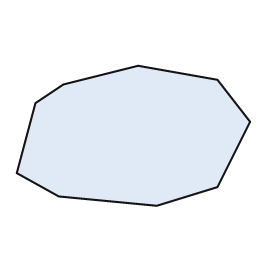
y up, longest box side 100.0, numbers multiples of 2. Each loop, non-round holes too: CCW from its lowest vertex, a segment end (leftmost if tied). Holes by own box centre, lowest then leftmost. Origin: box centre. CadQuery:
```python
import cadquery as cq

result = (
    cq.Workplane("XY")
    .moveTo(10.0, -30.0)
    .lineTo(36.0, -22.0)
    .lineTo(50.0, 6.0)
    .lineTo(36.0, 24.0)
    .lineTo(2.0, 30.0)
    .lineTo(-30.0, 22.0)
    .lineTo(-42.0, 14.0)
    .lineTo(-50.0, -16.0)
    .lineTo(-32.0, -26.0)
    .close()
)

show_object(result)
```